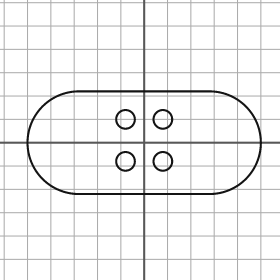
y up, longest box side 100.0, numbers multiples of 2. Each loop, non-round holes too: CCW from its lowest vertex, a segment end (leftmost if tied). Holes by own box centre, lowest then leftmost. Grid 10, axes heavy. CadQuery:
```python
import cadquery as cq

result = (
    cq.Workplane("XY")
    .moveTo(-28.0, -22.0)
    .lineTo(28.0, -22.0)
    .threePointArc((50.0, 0.0), (28.0, 22.0))
    .lineTo(-28.0, 22.0)
    .threePointArc((-50.0, 0.0), (-28.0, -22.0))
    .close()
    .moveTo(-8.0, -8.0)
    .circle(4.0)
    .moveTo(8.0, -8.0)
    .circle(4.0)
    .moveTo(-8.0, 10.0)
    .circle(4.0)
    .moveTo(8.0, 10.0)
    .circle(4.0)
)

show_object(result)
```